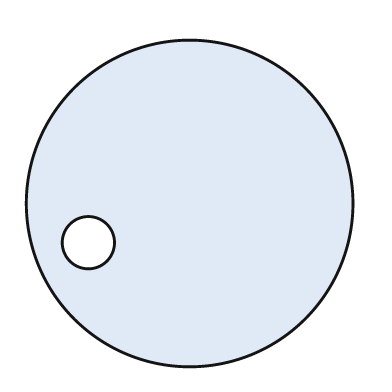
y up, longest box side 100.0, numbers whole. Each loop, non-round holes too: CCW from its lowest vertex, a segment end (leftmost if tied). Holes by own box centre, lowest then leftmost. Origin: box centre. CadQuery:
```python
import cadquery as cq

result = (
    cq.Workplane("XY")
    .moveTo(0.0, 0.0)
    .circle(50.0)
    .moveTo(-31.0, -12.0)
    .circle(8.0)
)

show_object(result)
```